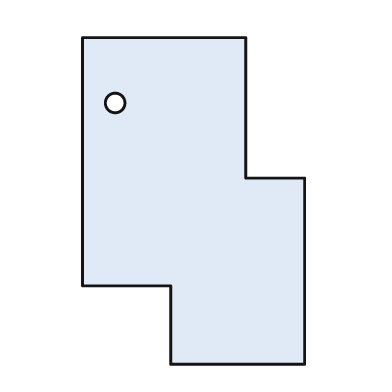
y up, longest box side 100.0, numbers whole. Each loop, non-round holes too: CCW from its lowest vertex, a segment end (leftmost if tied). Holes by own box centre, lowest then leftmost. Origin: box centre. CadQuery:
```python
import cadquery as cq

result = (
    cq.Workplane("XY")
    .moveTo(-7.0, -50.0)
    .lineTo(34.0, -50.0)
    .lineTo(34.0, 7.0)
    .lineTo(16.0, 7.0)
    .lineTo(16.0, 50.0)
    .lineTo(-34.0, 50.0)
    .lineTo(-34.0, -26.0)
    .lineTo(-7.0, -26.0)
    .close()
    .moveTo(-24.0, 30.0)
    .circle(3.0)
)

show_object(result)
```